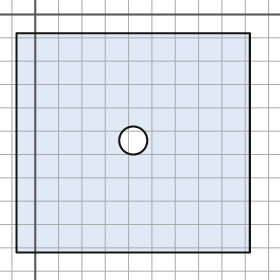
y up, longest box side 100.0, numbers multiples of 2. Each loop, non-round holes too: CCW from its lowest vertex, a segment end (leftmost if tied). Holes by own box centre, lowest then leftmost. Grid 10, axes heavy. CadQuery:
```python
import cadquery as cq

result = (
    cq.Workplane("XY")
    .moveTo(-8.0, -102.0)
    .lineTo(92.0, -102.0)
    .lineTo(92.0, -8.0)
    .lineTo(-8.0, -8.0)
    .close()
    .moveTo(42.0, -54.0)
    .circle(6.0)
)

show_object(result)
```